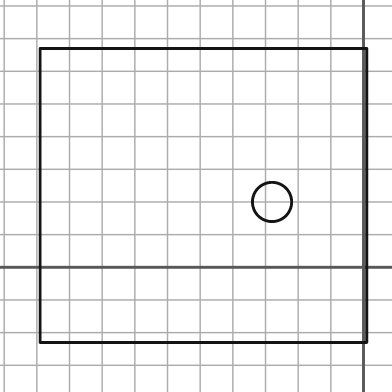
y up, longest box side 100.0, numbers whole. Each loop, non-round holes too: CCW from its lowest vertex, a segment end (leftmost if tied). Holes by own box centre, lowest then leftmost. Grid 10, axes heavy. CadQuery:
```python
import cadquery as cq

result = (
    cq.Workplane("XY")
    .moveTo(-99.0, -23.0)
    .lineTo(1.0, -23.0)
    .lineTo(1.0, 67.0)
    .lineTo(-99.0, 67.0)
    .close()
    .moveTo(-28.0, 20.0)
    .circle(6.0)
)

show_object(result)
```